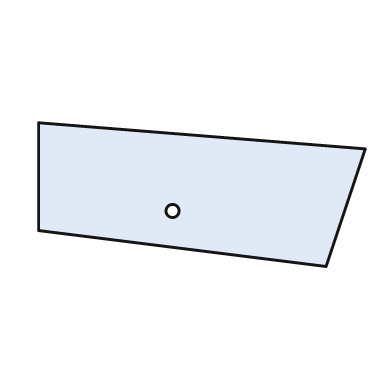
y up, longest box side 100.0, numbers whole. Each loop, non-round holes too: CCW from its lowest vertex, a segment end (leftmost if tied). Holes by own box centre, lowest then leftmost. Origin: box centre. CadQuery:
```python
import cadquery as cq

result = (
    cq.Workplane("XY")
    .moveTo(38.0, -22.0)
    .lineTo(50.0, 14.0)
    .lineTo(-50.0, 22.0)
    .lineTo(-50.0, -11.0)
    .close()
    .moveTo(-9.0, -5.0)
    .circle(2.0)
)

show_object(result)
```